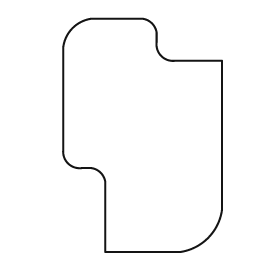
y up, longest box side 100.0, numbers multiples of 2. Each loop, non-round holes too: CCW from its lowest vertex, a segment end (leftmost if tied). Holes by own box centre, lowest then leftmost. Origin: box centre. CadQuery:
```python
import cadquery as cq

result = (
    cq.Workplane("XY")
    .moveTo(-16.0, -50.0)
    .lineTo(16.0, -50.0)
    .threePointArc((28.0, -44.0), (34.0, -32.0))
    .lineTo(34.0, 32.0)
    .lineTo(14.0, 32.0)
    .threePointArc((8.0, 34.0), (6.0, 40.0))
    .lineTo(6.0, 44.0)
    .threePointArc((4.0, 48.0), (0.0, 50.0))
    .lineTo(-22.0, 50.0)
    .threePointArc((-30.0, 46.0), (-34.0, 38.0))
    .lineTo(-34.0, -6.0)
    .threePointArc((-32.0, -12.0), (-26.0, -14.0))
    .lineTo(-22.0, -14.0)
    .threePointArc((-18.0, -16.0), (-16.0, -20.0))
    .close()
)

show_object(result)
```